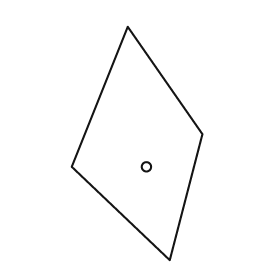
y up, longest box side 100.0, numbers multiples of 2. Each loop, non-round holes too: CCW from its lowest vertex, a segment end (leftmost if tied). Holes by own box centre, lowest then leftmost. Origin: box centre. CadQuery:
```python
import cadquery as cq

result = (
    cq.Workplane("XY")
    .moveTo(14.0, -50.0)
    .lineTo(28.0, 4.0)
    .lineTo(-4.0, 50.0)
    .lineTo(-28.0, -10.0)
    .close()
    .moveTo(4.0, -10.0)
    .circle(2.0)
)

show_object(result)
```